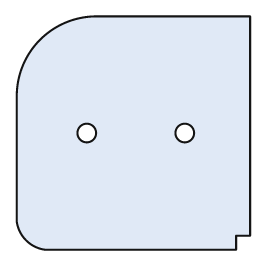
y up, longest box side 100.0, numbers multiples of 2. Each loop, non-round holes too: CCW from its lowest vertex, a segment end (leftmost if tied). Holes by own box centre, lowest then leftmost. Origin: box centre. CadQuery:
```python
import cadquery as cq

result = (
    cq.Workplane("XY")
    .moveTo(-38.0, -50.0)
    .lineTo(44.0, -50.0)
    .lineTo(44.0, -44.0)
    .lineTo(50.0, -44.0)
    .lineTo(50.0, 50.0)
    .lineTo(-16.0, 50.0)
    .threePointArc((-40.0, 40.0), (-50.0, 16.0))
    .lineTo(-50.0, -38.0)
    .threePointArc((-46.0, -46.0), (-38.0, -50.0))
    .close()
    .moveTo(-20.0, 0.0)
    .circle(4.0)
    .moveTo(22.0, 0.0)
    .circle(4.0)
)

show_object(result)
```